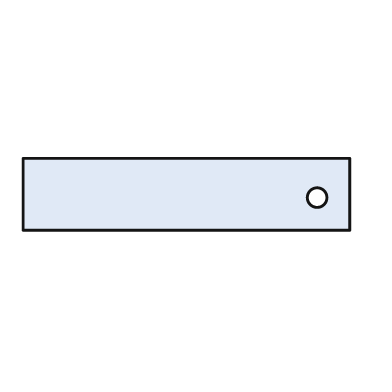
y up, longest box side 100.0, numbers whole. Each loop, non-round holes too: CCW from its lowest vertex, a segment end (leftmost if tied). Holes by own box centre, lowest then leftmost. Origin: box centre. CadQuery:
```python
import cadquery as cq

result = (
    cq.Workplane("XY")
    .moveTo(-50.0, -11.0)
    .lineTo(50.0, -11.0)
    .lineTo(50.0, 11.0)
    .lineTo(-50.0, 11.0)
    .close()
    .moveTo(40.0, -1.0)
    .circle(3.0)
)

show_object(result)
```